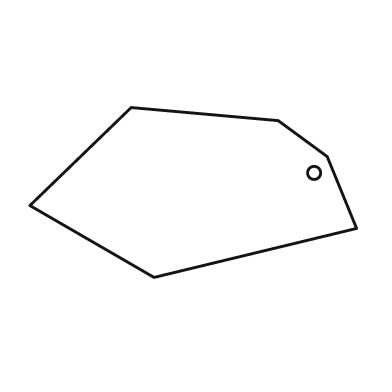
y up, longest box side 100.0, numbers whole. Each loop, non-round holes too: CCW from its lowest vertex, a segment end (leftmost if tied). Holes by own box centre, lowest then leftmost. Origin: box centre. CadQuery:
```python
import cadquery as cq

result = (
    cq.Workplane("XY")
    .moveTo(-12.0, -26.0)
    .lineTo(50.0, -11.0)
    .lineTo(41.0, 11.0)
    .lineTo(26.0, 22.0)
    .lineTo(-19.0, 26.0)
    .lineTo(-50.0, -4.0)
    .close()
    .moveTo(37.0, 6.0)
    .circle(2.0)
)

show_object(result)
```